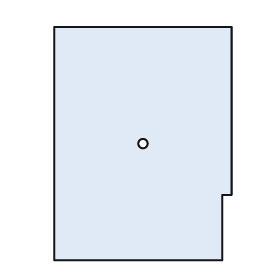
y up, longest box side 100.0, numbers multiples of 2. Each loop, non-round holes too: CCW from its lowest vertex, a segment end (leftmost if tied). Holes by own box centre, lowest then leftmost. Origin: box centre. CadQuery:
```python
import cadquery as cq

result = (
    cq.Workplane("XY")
    .moveTo(-38.0, -50.0)
    .lineTo(34.0, -50.0)
    .lineTo(34.0, -22.0)
    .lineTo(38.0, -22.0)
    .lineTo(38.0, 50.0)
    .lineTo(-38.0, 50.0)
    .close()
    .moveTo(0.0, 0.0)
    .circle(2.0)
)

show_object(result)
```